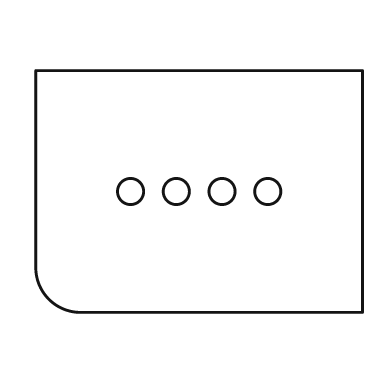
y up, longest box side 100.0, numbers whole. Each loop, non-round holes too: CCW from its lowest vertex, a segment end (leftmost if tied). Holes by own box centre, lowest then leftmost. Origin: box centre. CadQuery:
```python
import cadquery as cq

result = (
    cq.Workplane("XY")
    .moveTo(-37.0, -37.0)
    .lineTo(50.0, -37.0)
    .lineTo(50.0, 37.0)
    .lineTo(-50.0, 37.0)
    .lineTo(-50.0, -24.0)
    .threePointArc((-46.0, -33.0), (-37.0, -37.0))
    .close()
    .moveTo(-21.0, 0.0)
    .circle(4.0)
    .moveTo(-7.0, 0.0)
    .circle(4.0)
    .moveTo(7.0, 0.0)
    .circle(4.0)
    .moveTo(21.0, 0.0)
    .circle(4.0)
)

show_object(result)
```